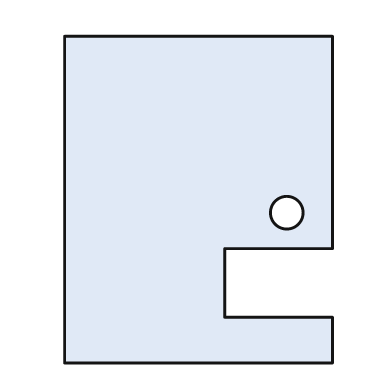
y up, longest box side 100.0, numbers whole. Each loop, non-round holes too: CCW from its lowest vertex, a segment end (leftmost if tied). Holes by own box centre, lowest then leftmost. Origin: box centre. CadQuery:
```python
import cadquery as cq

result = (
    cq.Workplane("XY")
    .moveTo(-41.0, -50.0)
    .lineTo(41.0, -50.0)
    .lineTo(41.0, -36.0)
    .lineTo(8.0, -36.0)
    .lineTo(8.0, -15.0)
    .lineTo(41.0, -15.0)
    .lineTo(41.0, 50.0)
    .lineTo(-41.0, 50.0)
    .close()
    .moveTo(27.0, -4.0)
    .circle(5.0)
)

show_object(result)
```